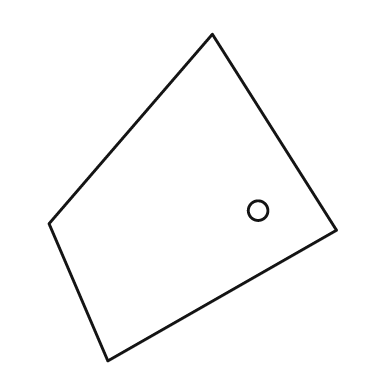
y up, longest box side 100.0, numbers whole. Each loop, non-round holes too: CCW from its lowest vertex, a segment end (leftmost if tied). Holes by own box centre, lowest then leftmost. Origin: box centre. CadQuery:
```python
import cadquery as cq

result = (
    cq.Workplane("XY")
    .moveTo(-26.0, -50.0)
    .lineTo(44.0, -10.0)
    .lineTo(6.0, 50.0)
    .lineTo(-44.0, -8.0)
    .close()
    .moveTo(20.0, -4.0)
    .circle(3.0)
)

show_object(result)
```